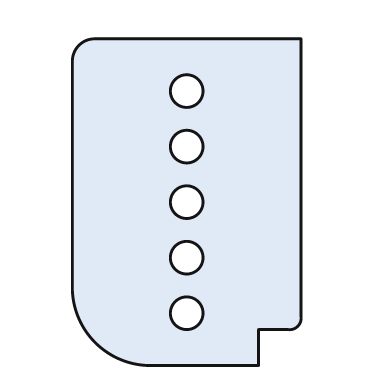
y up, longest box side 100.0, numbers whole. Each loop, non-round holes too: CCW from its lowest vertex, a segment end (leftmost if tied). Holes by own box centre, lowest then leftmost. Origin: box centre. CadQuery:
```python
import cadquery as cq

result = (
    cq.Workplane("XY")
    .moveTo(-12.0, -50.0)
    .lineTo(22.0, -50.0)
    .lineTo(22.0, -39.0)
    .lineTo(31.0, -39.0)
    .threePointArc((34.0, -38.0), (35.0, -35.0))
    .lineTo(35.0, 50.0)
    .lineTo(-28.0, 50.0)
    .threePointArc((-33.0, 48.0), (-35.0, 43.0))
    .lineTo(-35.0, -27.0)
    .threePointArc((-28.0, -43.0), (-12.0, -50.0))
    .close()
    .moveTo(0.0, -34.0)
    .circle(5.0)
    .moveTo(0.0, -17.0)
    .circle(5.0)
    .moveTo(0.0, 0.0)
    .circle(5.0)
    .moveTo(0.0, 17.0)
    .circle(5.0)
    .moveTo(0.0, 34.0)
    .circle(5.0)
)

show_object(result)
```